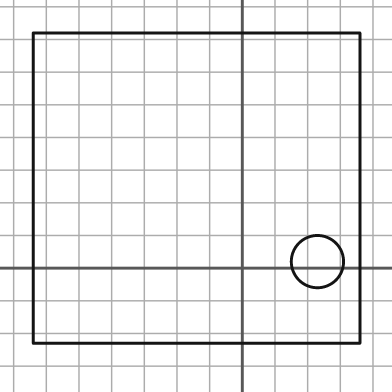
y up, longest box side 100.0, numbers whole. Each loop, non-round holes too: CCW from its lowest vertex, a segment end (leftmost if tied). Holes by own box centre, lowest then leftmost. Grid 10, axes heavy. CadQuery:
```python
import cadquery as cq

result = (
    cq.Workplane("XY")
    .moveTo(-64.0, -23.0)
    .lineTo(36.0, -23.0)
    .lineTo(36.0, 72.0)
    .lineTo(-64.0, 72.0)
    .close()
    .moveTo(23.0, 2.0)
    .circle(8.0)
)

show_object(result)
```